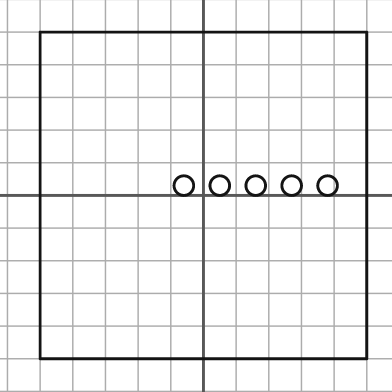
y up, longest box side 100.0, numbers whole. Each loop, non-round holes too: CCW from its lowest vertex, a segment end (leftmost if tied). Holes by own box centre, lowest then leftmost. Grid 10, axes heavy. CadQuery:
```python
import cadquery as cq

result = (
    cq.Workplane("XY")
    .moveTo(-50.0, -50.0)
    .lineTo(50.0, -50.0)
    .lineTo(50.0, 50.0)
    .lineTo(-50.0, 50.0)
    .close()
    .moveTo(-6.0, 3.0)
    .circle(3.0)
    .moveTo(5.0, 3.0)
    .circle(3.0)
    .moveTo(16.0, 3.0)
    .circle(3.0)
    .moveTo(27.0, 3.0)
    .circle(3.0)
    .moveTo(38.0, 3.0)
    .circle(3.0)
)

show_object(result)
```